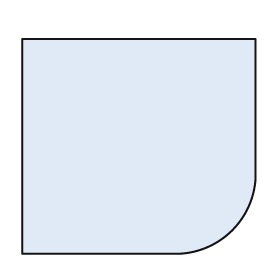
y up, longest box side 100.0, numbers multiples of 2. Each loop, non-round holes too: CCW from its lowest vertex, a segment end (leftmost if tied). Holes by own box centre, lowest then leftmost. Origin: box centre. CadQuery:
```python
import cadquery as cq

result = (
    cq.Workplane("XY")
    .moveTo(-50.0, -46.0)
    .lineTo(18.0, -46.0)
    .threePointArc((40.0, -36.0), (50.0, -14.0))
    .lineTo(50.0, 46.0)
    .lineTo(-50.0, 46.0)
    .close()
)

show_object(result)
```